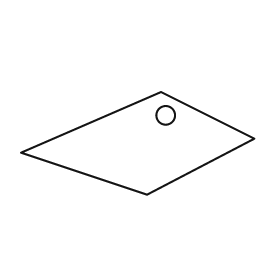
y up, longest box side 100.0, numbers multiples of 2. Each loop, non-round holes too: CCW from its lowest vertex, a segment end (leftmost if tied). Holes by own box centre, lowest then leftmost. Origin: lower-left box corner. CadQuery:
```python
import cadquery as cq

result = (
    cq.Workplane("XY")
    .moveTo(54.0, 0.0)
    .lineTo(100.0, 24.0)
    .lineTo(60.0, 44.0)
    .lineTo(0.0, 18.0)
    .close()
    .moveTo(62.0, 34.0)
    .circle(4.0)
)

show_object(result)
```